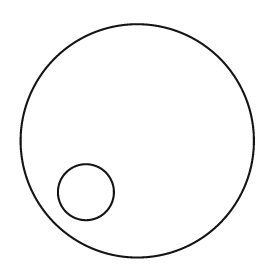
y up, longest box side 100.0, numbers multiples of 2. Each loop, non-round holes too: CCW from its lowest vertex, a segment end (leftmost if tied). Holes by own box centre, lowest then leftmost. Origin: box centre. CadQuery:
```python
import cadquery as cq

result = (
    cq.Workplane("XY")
    .moveTo(0.0, 0.0)
    .circle(50.0)
    .moveTo(-22.0, -22.0)
    .circle(12.0)
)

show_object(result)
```